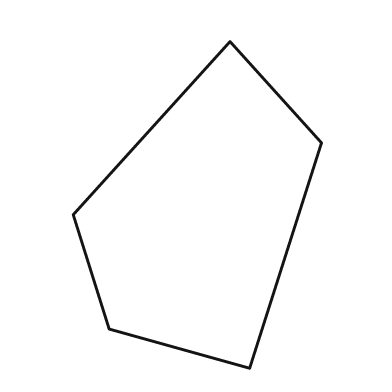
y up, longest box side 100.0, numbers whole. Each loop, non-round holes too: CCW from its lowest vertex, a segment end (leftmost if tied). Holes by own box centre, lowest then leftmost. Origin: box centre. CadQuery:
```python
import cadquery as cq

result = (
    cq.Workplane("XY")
    .moveTo(16.0, -50.0)
    .lineTo(38.0, 19.0)
    .lineTo(10.0, 50.0)
    .lineTo(-38.0, -3.0)
    .lineTo(-27.0, -38.0)
    .close()
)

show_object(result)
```